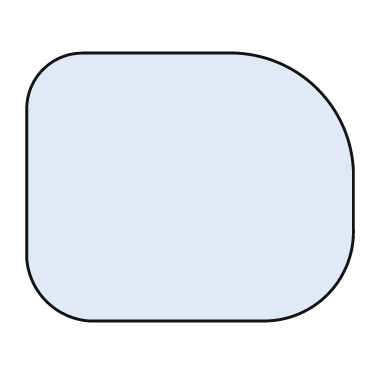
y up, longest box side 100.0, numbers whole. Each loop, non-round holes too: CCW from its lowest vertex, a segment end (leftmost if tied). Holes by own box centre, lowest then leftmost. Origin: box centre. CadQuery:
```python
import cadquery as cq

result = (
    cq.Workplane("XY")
    .moveTo(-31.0, -41.0)
    .lineTo(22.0, -41.0)
    .threePointArc((42.0, -33.0), (50.0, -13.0))
    .lineTo(50.0, 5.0)
    .threePointArc((39.0, 30.0), (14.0, 41.0))
    .lineTo(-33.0, 41.0)
    .threePointArc((-45.0, 36.0), (-50.0, 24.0))
    .lineTo(-50.0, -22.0)
    .threePointArc((-44.0, -35.0), (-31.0, -41.0))
    .close()
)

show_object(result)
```